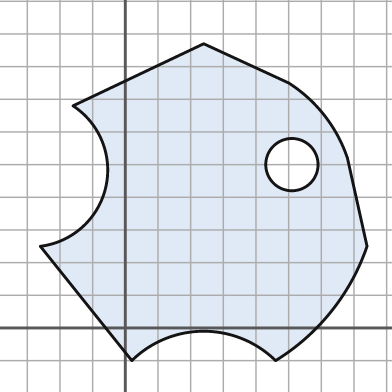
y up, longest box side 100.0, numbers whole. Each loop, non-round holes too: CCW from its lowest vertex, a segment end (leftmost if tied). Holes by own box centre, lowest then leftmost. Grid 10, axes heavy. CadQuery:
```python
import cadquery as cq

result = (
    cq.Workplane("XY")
    .moveTo(2.0, -10.0)
    .threePointArc((24.0, -1.0), (46.0, -10.0))
    .threePointArc((63.0, 5.0), (74.0, 25.0))
    .lineTo(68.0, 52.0)
    .threePointArc((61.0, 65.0), (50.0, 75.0))
    .lineTo(24.0, 87.0)
    .lineTo(-16.0, 68.0)
    .threePointArc((-6.0, 43.0), (-26.0, 25.0))
    .close()
    .moveTo(51.0, 50.0)
    .circle(8.0)
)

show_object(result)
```